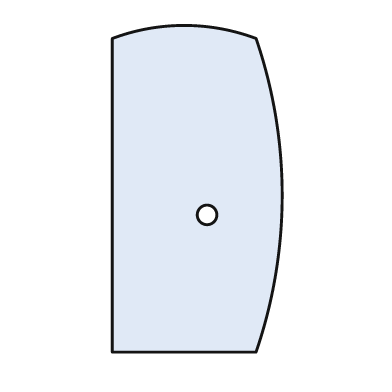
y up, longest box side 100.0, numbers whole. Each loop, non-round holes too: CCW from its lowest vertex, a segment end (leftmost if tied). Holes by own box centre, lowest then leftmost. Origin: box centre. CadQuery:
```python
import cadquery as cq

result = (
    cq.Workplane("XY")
    .moveTo(-26.0, -50.0)
    .lineTo(18.0, -50.0)
    .threePointArc((26.0, -2.0), (18.0, 46.0))
    .threePointArc((-4.0, 50.0), (-26.0, 46.0))
    .close()
    .moveTo(3.0, -8.0)
    .circle(3.0)
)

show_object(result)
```